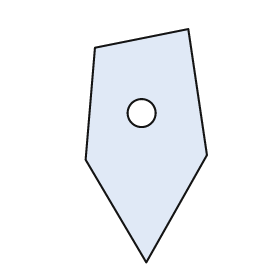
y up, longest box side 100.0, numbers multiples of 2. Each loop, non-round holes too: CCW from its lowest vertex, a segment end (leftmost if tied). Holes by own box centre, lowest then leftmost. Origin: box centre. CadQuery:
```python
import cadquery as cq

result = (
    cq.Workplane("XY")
    .moveTo(0.0, -50.0)
    .lineTo(26.0, -4.0)
    .lineTo(18.0, 50.0)
    .lineTo(-22.0, 42.0)
    .lineTo(-26.0, -6.0)
    .close()
    .moveTo(-2.0, 14.0)
    .circle(6.0)
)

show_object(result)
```